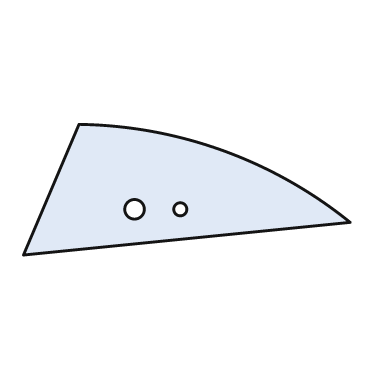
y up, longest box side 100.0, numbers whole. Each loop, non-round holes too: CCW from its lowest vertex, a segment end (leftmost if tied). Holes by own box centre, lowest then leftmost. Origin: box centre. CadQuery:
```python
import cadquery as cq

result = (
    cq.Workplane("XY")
    .moveTo(-50.0, -20.0)
    .lineTo(50.0, -10.0)
    .threePointArc((11.0, 12.0), (-33.0, 20.0))
    .close()
    .moveTo(-16.0, -6.0)
    .circle(3.0)
    .moveTo(-2.0, -6.0)
    .circle(2.0)
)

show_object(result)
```